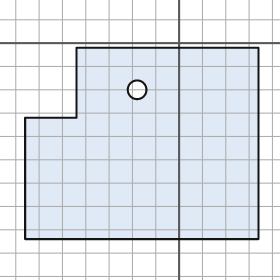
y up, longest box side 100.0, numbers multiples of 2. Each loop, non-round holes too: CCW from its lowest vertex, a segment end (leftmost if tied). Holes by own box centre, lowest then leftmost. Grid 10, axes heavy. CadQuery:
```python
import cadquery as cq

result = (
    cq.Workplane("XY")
    .moveTo(-66.0, -84.0)
    .lineTo(34.0, -84.0)
    .lineTo(34.0, -2.0)
    .lineTo(-44.0, -2.0)
    .lineTo(-44.0, -32.0)
    .lineTo(-66.0, -32.0)
    .close()
    .moveTo(-18.0, -20.0)
    .circle(4.0)
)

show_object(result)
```